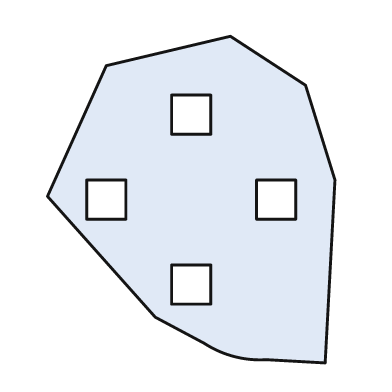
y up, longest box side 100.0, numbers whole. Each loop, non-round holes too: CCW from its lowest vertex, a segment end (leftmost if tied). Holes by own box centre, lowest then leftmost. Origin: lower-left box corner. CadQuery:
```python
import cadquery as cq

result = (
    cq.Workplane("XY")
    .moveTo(85.0, 0.0)
    .lineTo(88.0, 56.0)
    .lineTo(79.0, 85.0)
    .lineTo(56.0, 100.0)
    .lineTo(18.0, 91.0)
    .lineTo(0.0, 51.0)
    .lineTo(33.0, 14.0)
    .lineTo(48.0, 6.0)
    .threePointArc((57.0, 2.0), (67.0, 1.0))
    .close()
    .moveTo(38.0, 18.0)
    .lineTo(50.0, 18.0)
    .lineTo(50.0, 30.0)
    .lineTo(38.0, 30.0)
    .close()
    .moveTo(12.0, 44.0)
    .lineTo(24.0, 44.0)
    .lineTo(24.0, 56.0)
    .lineTo(12.0, 56.0)
    .close()
    .moveTo(64.0, 44.0)
    .lineTo(76.0, 44.0)
    .lineTo(76.0, 56.0)
    .lineTo(64.0, 56.0)
    .close()
    .moveTo(38.0, 70.0)
    .lineTo(50.0, 70.0)
    .lineTo(50.0, 82.0)
    .lineTo(38.0, 82.0)
    .close()
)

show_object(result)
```